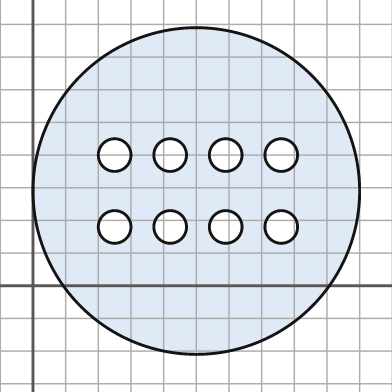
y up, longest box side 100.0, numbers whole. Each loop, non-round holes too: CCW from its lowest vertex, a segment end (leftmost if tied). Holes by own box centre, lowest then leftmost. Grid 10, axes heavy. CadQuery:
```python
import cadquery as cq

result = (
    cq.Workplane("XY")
    .moveTo(50.0, 29.0)
    .circle(50.0)
    .moveTo(25.0, 18.0)
    .circle(5.0)
    .moveTo(42.0, 18.0)
    .circle(5.0)
    .moveTo(59.0, 18.0)
    .circle(5.0)
    .moveTo(76.0, 18.0)
    .circle(5.0)
    .moveTo(25.0, 40.0)
    .circle(5.0)
    .moveTo(42.0, 40.0)
    .circle(5.0)
    .moveTo(59.0, 40.0)
    .circle(5.0)
    .moveTo(76.0, 40.0)
    .circle(5.0)
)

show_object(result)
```